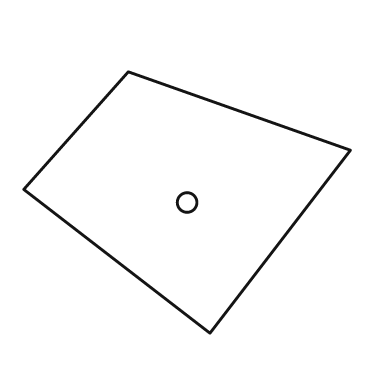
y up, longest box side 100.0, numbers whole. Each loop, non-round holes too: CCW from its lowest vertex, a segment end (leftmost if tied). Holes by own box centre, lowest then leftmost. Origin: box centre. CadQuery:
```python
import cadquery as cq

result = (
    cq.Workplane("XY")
    .moveTo(7.0, -40.0)
    .lineTo(50.0, 16.0)
    .lineTo(-18.0, 40.0)
    .lineTo(-50.0, 4.0)
    .close()
    .moveTo(0.0, 0.0)
    .circle(3.0)
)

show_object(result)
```